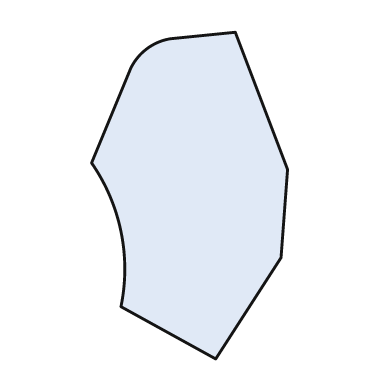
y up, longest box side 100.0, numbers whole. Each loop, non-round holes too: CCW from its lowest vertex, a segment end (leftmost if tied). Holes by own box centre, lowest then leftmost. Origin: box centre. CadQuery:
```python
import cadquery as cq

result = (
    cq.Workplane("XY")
    .moveTo(8.0, -50.0)
    .lineTo(28.0, -19.0)
    .lineTo(30.0, 8.0)
    .lineTo(14.0, 50.0)
    .lineTo(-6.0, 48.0)
    .threePointArc((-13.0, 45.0), (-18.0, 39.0))
    .lineTo(-30.0, 10.0)
    .threePointArc((-21.0, -11.0), (-21.0, -34.0))
    .close()
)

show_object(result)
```